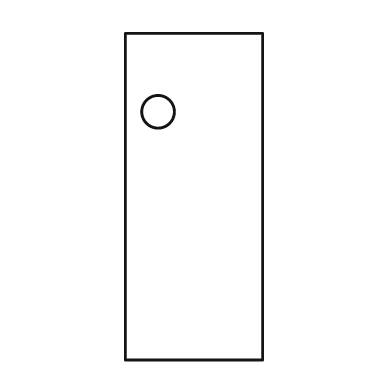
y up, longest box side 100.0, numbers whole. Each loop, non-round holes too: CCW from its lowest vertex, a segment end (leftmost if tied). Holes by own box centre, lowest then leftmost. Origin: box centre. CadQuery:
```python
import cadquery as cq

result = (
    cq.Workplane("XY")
    .moveTo(-21.0, -50.0)
    .lineTo(21.0, -50.0)
    .lineTo(21.0, 50.0)
    .lineTo(-21.0, 50.0)
    .close()
    .moveTo(-11.0, 26.0)
    .circle(5.0)
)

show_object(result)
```